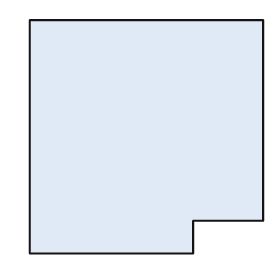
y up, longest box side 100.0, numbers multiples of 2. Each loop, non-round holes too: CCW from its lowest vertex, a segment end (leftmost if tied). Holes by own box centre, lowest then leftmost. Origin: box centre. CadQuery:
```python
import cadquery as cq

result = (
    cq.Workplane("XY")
    .moveTo(-50.0, -50.0)
    .lineTo(20.0, -50.0)
    .lineTo(20.0, -36.0)
    .lineTo(50.0, -36.0)
    .lineTo(50.0, 50.0)
    .lineTo(-50.0, 50.0)
    .close()
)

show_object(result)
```